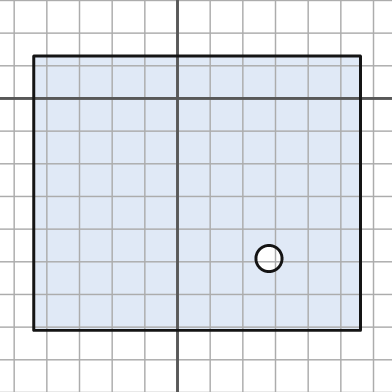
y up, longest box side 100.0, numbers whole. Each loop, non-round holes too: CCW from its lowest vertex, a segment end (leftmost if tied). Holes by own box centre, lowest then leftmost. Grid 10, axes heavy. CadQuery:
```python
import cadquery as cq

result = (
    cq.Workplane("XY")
    .moveTo(-44.0, -71.0)
    .lineTo(56.0, -71.0)
    .lineTo(56.0, 13.0)
    .lineTo(-44.0, 13.0)
    .close()
    .moveTo(28.0, -49.0)
    .circle(4.0)
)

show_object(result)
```